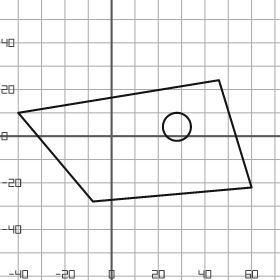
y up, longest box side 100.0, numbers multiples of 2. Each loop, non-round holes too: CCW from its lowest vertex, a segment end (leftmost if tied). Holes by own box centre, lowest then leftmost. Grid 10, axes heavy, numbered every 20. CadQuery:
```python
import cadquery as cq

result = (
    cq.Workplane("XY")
    .moveTo(-8.0, -28.0)
    .lineTo(60.0, -22.0)
    .lineTo(46.0, 24.0)
    .lineTo(-40.0, 10.0)
    .close()
    .moveTo(28.0, 4.0)
    .circle(6.0)
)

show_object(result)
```